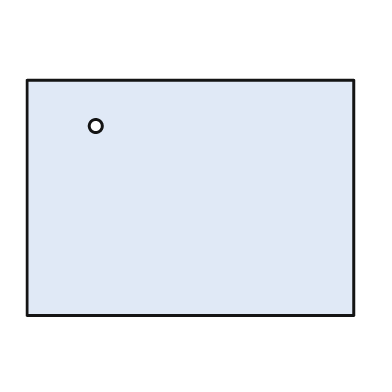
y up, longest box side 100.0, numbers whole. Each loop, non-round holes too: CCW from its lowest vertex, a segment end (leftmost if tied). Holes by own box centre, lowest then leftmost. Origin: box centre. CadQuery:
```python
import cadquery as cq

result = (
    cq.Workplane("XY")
    .moveTo(-50.0, -36.0)
    .lineTo(50.0, -36.0)
    .lineTo(50.0, 36.0)
    .lineTo(-50.0, 36.0)
    .close()
    .moveTo(-29.0, 22.0)
    .circle(2.0)
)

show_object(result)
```